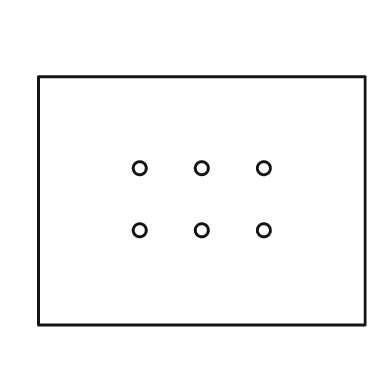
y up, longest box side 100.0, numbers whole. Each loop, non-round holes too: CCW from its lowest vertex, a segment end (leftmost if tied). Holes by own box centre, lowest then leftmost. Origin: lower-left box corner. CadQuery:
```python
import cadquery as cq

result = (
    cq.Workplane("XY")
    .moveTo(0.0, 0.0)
    .lineTo(100.0, 0.0)
    .lineTo(100.0, 76.0)
    .lineTo(0.0, 76.0)
    .close()
    .moveTo(31.0, 29.0)
    .circle(2.0)
    .moveTo(50.0, 29.0)
    .circle(2.0)
    .moveTo(69.0, 29.0)
    .circle(2.0)
    .moveTo(31.0, 48.0)
    .circle(2.0)
    .moveTo(50.0, 48.0)
    .circle(2.0)
    .moveTo(69.0, 48.0)
    .circle(2.0)
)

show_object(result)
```